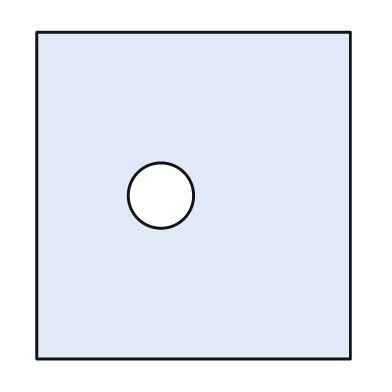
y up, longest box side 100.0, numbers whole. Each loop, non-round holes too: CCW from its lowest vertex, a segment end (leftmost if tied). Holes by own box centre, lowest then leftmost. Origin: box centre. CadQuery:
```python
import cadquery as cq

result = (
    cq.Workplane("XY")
    .moveTo(-48.0, -50.0)
    .lineTo(48.0, -50.0)
    .lineTo(48.0, 50.0)
    .lineTo(-48.0, 50.0)
    .close()
    .moveTo(-10.0, 0.0)
    .circle(10.0)
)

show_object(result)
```